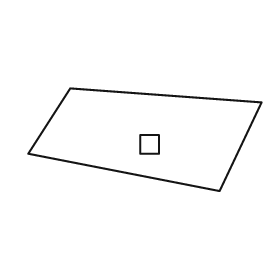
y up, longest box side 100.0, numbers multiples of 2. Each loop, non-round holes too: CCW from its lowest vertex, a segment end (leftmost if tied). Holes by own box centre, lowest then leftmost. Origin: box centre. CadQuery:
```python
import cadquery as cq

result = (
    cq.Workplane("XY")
    .moveTo(32.0, -22.0)
    .lineTo(50.0, 16.0)
    .lineTo(-32.0, 22.0)
    .lineTo(-50.0, -6.0)
    .close()
    .moveTo(-2.0, -6.0)
    .lineTo(6.0, -6.0)
    .lineTo(6.0, 2.0)
    .lineTo(-2.0, 2.0)
    .close()
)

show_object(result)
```